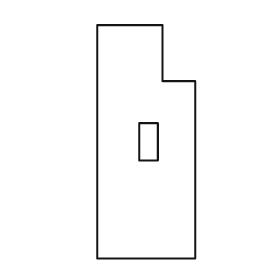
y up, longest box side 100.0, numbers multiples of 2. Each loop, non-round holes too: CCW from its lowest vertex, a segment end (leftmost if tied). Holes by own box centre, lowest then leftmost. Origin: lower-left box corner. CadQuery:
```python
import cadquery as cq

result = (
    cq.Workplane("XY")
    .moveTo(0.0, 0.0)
    .lineTo(42.0, 0.0)
    .lineTo(42.0, 76.0)
    .lineTo(28.0, 76.0)
    .lineTo(28.0, 100.0)
    .lineTo(0.0, 100.0)
    .close()
    .moveTo(18.0, 42.0)
    .lineTo(26.0, 42.0)
    .lineTo(26.0, 58.0)
    .lineTo(18.0, 58.0)
    .close()
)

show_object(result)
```